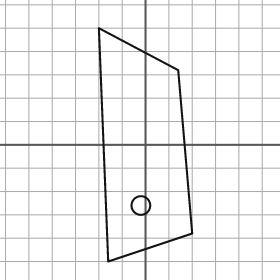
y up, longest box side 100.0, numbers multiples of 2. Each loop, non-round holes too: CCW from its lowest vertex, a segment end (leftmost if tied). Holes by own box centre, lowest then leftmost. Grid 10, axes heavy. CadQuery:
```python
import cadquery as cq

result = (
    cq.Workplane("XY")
    .moveTo(-16.0, -50.0)
    .lineTo(20.0, -38.0)
    .lineTo(14.0, 32.0)
    .lineTo(-20.0, 50.0)
    .close()
    .moveTo(-2.0, -26.0)
    .circle(4.0)
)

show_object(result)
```